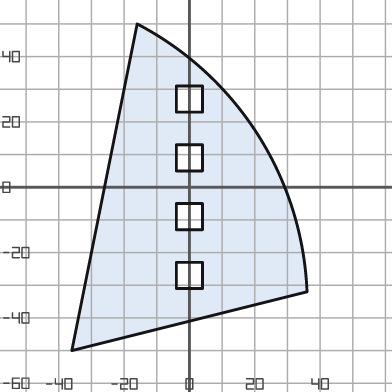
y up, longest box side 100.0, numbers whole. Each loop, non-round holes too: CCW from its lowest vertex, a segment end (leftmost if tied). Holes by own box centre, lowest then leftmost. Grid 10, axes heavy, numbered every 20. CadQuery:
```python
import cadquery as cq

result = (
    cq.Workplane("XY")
    .moveTo(-36.0, -50.0)
    .lineTo(36.0, -32.0)
    .threePointArc((21.0, 16.0), (-16.0, 50.0))
    .close()
    .moveTo(-4.0, -31.0)
    .lineTo(4.0, -31.0)
    .lineTo(4.0, -23.0)
    .lineTo(-4.0, -23.0)
    .close()
    .moveTo(-4.0, -13.0)
    .lineTo(4.0, -13.0)
    .lineTo(4.0, -5.0)
    .lineTo(-4.0, -5.0)
    .close()
    .moveTo(-4.0, 5.0)
    .lineTo(4.0, 5.0)
    .lineTo(4.0, 13.0)
    .lineTo(-4.0, 13.0)
    .close()
    .moveTo(-4.0, 23.0)
    .lineTo(4.0, 23.0)
    .lineTo(4.0, 31.0)
    .lineTo(-4.0, 31.0)
    .close()
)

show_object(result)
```